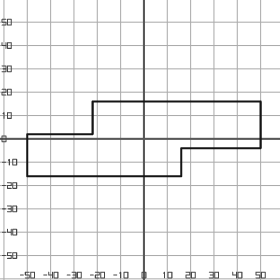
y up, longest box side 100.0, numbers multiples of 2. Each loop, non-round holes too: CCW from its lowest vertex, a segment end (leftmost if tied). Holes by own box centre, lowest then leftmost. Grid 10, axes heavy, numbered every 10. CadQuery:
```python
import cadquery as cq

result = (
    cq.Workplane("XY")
    .moveTo(-50.0, -16.0)
    .lineTo(16.0, -16.0)
    .lineTo(16.0, -4.0)
    .lineTo(50.0, -4.0)
    .lineTo(50.0, 16.0)
    .lineTo(-22.0, 16.0)
    .lineTo(-22.0, 2.0)
    .lineTo(-50.0, 2.0)
    .close()
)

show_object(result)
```